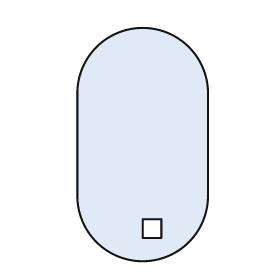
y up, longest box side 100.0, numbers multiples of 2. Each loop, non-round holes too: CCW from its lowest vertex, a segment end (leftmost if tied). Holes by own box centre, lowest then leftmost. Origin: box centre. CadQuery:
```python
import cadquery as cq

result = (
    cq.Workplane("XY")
    .moveTo(-28.0, -22.0)
    .threePointArc((0.0, -50.0), (28.0, -22.0))
    .lineTo(28.0, 22.0)
    .threePointArc((0.0, 50.0), (-28.0, 22.0))
    .close()
    .moveTo(0.0, -40.0)
    .lineTo(8.0, -40.0)
    .lineTo(8.0, -32.0)
    .lineTo(0.0, -32.0)
    .close()
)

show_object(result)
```